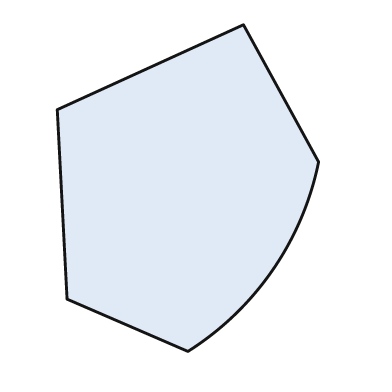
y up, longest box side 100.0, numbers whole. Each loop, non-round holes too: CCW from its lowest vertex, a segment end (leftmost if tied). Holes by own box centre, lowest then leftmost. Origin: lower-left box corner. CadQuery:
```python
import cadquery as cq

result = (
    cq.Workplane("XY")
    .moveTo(40.0, 0.0)
    .threePointArc((66.0, 25.0), (80.0, 58.0))
    .lineTo(57.0, 100.0)
    .lineTo(0.0, 74.0)
    .lineTo(3.0, 16.0)
    .close()
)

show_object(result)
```